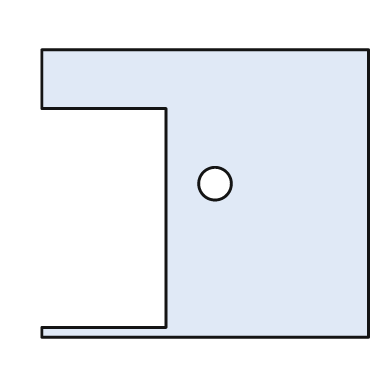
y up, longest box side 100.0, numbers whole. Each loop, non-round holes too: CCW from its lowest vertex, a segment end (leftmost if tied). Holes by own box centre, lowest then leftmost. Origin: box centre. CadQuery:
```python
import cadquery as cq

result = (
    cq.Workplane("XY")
    .moveTo(-50.0, -44.0)
    .lineTo(50.0, -44.0)
    .lineTo(50.0, 44.0)
    .lineTo(-50.0, 44.0)
    .lineTo(-50.0, 26.0)
    .lineTo(-12.0, 26.0)
    .lineTo(-12.0, -41.0)
    .lineTo(-50.0, -41.0)
    .close()
    .moveTo(3.0, 3.0)
    .circle(5.0)
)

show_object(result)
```